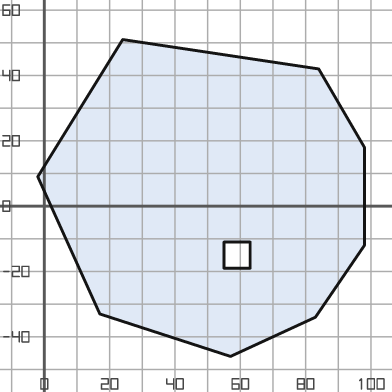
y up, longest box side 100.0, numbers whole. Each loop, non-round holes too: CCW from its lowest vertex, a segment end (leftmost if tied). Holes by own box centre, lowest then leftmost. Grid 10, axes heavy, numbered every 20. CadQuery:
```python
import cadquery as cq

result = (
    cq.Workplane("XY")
    .moveTo(57.0, -46.0)
    .lineTo(83.0, -34.0)
    .lineTo(98.0, -12.0)
    .lineTo(98.0, 18.0)
    .lineTo(84.0, 42.0)
    .lineTo(24.0, 51.0)
    .lineTo(-2.0, 9.0)
    .lineTo(17.0, -33.0)
    .close()
    .moveTo(55.0, -19.0)
    .lineTo(63.0, -19.0)
    .lineTo(63.0, -11.0)
    .lineTo(55.0, -11.0)
    .close()
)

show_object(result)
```